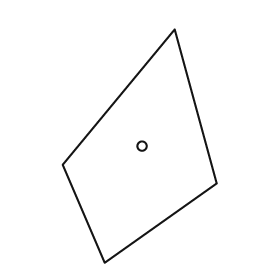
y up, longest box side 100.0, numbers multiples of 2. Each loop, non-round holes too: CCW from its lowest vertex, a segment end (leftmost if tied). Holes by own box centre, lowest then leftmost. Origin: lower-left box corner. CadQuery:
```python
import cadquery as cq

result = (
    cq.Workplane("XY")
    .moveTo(18.0, 0.0)
    .lineTo(66.0, 34.0)
    .lineTo(48.0, 100.0)
    .lineTo(0.0, 42.0)
    .close()
    .moveTo(34.0, 50.0)
    .circle(2.0)
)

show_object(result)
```